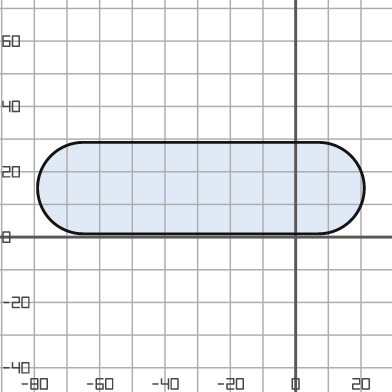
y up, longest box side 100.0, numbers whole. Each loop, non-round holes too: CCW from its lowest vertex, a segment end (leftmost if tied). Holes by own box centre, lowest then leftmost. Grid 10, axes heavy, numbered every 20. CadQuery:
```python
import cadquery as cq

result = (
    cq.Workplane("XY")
    .moveTo(-65.0, 1.0)
    .lineTo(7.0, 1.0)
    .threePointArc((21.0, 15.0), (7.0, 29.0))
    .lineTo(-65.0, 29.0)
    .threePointArc((-79.0, 15.0), (-65.0, 1.0))
    .close()
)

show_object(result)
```